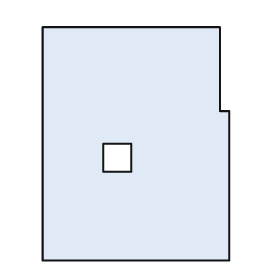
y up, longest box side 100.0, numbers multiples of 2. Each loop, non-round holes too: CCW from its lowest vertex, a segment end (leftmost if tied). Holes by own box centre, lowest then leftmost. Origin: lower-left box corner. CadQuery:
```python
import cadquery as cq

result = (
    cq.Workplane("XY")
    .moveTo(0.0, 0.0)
    .lineTo(80.0, 0.0)
    .lineTo(80.0, 64.0)
    .lineTo(76.0, 64.0)
    .lineTo(76.0, 100.0)
    .lineTo(0.0, 100.0)
    .close()
    .moveTo(26.0, 38.0)
    .lineTo(38.0, 38.0)
    .lineTo(38.0, 50.0)
    .lineTo(26.0, 50.0)
    .close()
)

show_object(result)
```